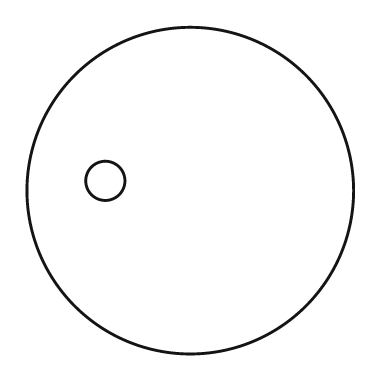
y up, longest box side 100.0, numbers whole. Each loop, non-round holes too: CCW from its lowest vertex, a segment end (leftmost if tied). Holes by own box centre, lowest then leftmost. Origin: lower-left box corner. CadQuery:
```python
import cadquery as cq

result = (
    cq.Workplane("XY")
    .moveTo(50.0, 50.0)
    .circle(50.0)
    .moveTo(24.0, 53.0)
    .circle(6.0)
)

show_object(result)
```